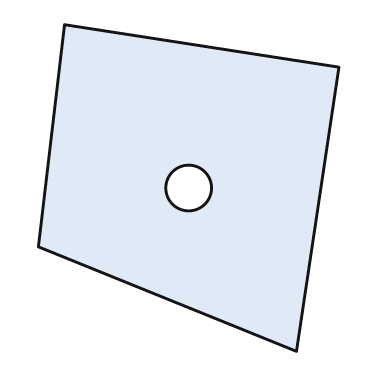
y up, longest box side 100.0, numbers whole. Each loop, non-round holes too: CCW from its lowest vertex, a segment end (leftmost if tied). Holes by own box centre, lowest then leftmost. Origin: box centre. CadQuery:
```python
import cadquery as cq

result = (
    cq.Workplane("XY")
    .moveTo(33.0, -50.0)
    .lineTo(46.0, 37.0)
    .lineTo(-38.0, 50.0)
    .lineTo(-46.0, -18.0)
    .close()
    .moveTo(0.0, 0.0)
    .circle(7.0)
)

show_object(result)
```